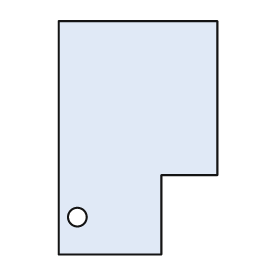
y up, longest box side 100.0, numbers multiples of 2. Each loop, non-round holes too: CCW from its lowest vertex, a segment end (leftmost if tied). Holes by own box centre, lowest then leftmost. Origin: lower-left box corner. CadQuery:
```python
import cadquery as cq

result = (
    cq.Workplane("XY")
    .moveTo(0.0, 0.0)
    .lineTo(44.0, 0.0)
    .lineTo(44.0, 34.0)
    .lineTo(68.0, 34.0)
    .lineTo(68.0, 100.0)
    .lineTo(0.0, 100.0)
    .close()
    .moveTo(8.0, 16.0)
    .circle(4.0)
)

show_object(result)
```